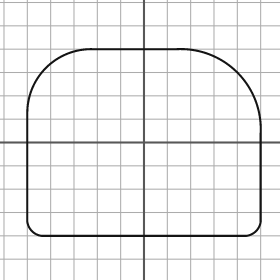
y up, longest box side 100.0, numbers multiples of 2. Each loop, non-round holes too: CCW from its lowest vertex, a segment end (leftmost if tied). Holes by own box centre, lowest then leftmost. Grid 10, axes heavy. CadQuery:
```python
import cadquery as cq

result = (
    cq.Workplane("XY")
    .moveTo(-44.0, -40.0)
    .lineTo(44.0, -40.0)
    .threePointArc((48.0, -38.0), (50.0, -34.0))
    .lineTo(50.0, 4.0)
    .threePointArc((40.0, 30.0), (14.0, 40.0))
    .lineTo(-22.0, 40.0)
    .threePointArc((-42.0, 32.0), (-50.0, 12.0))
    .lineTo(-50.0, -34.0)
    .threePointArc((-48.0, -38.0), (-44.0, -40.0))
    .close()
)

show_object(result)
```